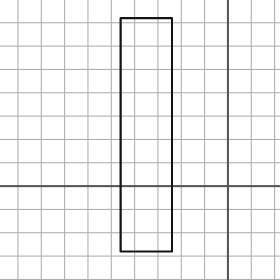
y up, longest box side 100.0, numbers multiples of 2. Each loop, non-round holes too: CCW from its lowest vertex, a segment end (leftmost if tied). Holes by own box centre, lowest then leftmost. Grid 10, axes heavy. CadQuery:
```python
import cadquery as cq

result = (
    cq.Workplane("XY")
    .moveTo(-46.0, -28.0)
    .lineTo(-24.0, -28.0)
    .lineTo(-24.0, 72.0)
    .lineTo(-46.0, 72.0)
    .close()
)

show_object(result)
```